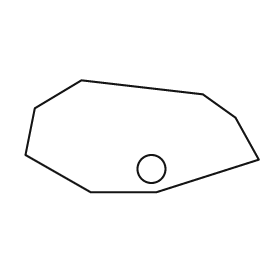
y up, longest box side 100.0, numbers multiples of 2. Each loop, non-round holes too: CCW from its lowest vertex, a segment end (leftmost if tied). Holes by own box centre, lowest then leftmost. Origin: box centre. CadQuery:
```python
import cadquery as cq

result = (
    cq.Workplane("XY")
    .moveTo(-22.0, -24.0)
    .lineTo(6.0, -24.0)
    .lineTo(50.0, -10.0)
    .lineTo(40.0, 8.0)
    .lineTo(26.0, 18.0)
    .lineTo(-26.0, 24.0)
    .lineTo(-46.0, 12.0)
    .lineTo(-50.0, -8.0)
    .close()
    .moveTo(4.0, -14.0)
    .circle(6.0)
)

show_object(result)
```